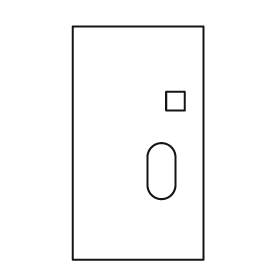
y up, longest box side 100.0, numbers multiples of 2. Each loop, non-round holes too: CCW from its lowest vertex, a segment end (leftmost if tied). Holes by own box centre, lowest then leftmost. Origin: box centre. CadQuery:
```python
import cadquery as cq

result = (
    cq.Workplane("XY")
    .moveTo(-28.0, -50.0)
    .lineTo(28.0, -50.0)
    .lineTo(28.0, 50.0)
    .lineTo(-28.0, 50.0)
    .close()
    .moveTo(4.0, -18.0)
    .threePointArc((10.0, -24.0), (16.0, -18.0))
    .lineTo(16.0, -6.0)
    .threePointArc((10.0, 0.0), (4.0, -6.0))
    .close()
    .moveTo(12.0, 14.0)
    .lineTo(20.0, 14.0)
    .lineTo(20.0, 22.0)
    .lineTo(12.0, 22.0)
    .close()
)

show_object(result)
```